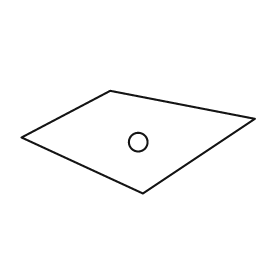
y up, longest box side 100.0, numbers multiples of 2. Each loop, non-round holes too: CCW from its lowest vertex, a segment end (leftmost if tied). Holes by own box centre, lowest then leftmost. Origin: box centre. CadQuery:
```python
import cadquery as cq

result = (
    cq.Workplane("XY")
    .moveTo(2.0, -22.0)
    .lineTo(50.0, 10.0)
    .lineTo(-12.0, 22.0)
    .lineTo(-50.0, 2.0)
    .close()
    .moveTo(0.0, 0.0)
    .circle(4.0)
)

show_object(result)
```